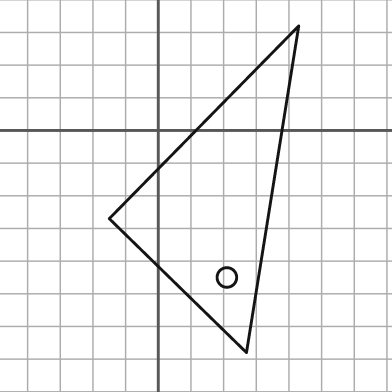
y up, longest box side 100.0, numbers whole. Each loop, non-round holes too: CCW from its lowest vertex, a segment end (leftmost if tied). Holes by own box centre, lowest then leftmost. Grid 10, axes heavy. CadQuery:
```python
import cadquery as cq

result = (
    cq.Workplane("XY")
    .moveTo(27.0, -68.0)
    .lineTo(43.0, 32.0)
    .lineTo(-15.0, -27.0)
    .close()
    .moveTo(21.0, -45.0)
    .circle(3.0)
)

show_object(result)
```